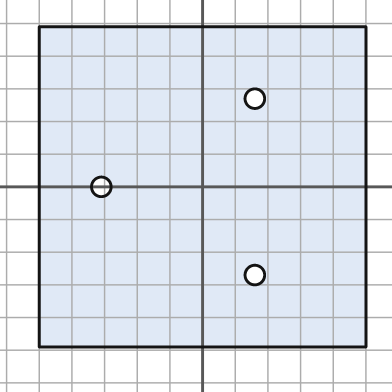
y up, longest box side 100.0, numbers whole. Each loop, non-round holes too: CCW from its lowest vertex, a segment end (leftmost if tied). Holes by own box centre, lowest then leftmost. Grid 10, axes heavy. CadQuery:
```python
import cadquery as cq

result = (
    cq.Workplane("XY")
    .moveTo(-50.0, -49.0)
    .lineTo(50.0, -49.0)
    .lineTo(50.0, 49.0)
    .lineTo(-50.0, 49.0)
    .close()
    .moveTo(16.0, -27.0)
    .circle(3.0)
    .moveTo(-31.0, 0.0)
    .circle(3.0)
    .moveTo(16.0, 27.0)
    .circle(3.0)
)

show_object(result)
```